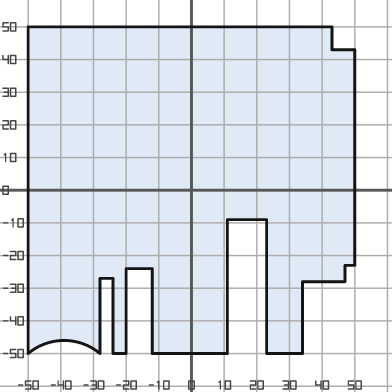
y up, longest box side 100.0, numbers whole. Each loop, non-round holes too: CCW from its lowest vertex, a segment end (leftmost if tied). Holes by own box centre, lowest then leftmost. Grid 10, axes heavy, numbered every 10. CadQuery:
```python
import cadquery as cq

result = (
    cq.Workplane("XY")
    .moveTo(-50.0, -50.0)
    .threePointArc((-39.0, -46.0), (-28.0, -50.0))
    .lineTo(-28.0, -27.0)
    .lineTo(-24.0, -27.0)
    .lineTo(-24.0, -50.0)
    .lineTo(-20.0, -50.0)
    .lineTo(-20.0, -24.0)
    .lineTo(-12.0, -24.0)
    .lineTo(-12.0, -50.0)
    .lineTo(11.0, -50.0)
    .lineTo(11.0, -9.0)
    .lineTo(23.0, -9.0)
    .lineTo(23.0, -50.0)
    .lineTo(34.0, -50.0)
    .lineTo(34.0, -28.0)
    .lineTo(47.0, -28.0)
    .lineTo(47.0, -23.0)
    .lineTo(50.0, -23.0)
    .lineTo(50.0, 43.0)
    .lineTo(43.0, 43.0)
    .lineTo(43.0, 50.0)
    .lineTo(-50.0, 50.0)
    .close()
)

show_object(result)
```